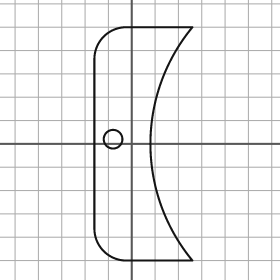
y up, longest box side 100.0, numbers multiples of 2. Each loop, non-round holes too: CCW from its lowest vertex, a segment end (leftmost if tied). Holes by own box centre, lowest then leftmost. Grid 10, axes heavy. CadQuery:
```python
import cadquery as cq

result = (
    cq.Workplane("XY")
    .moveTo(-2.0, -50.0)
    .lineTo(26.0, -50.0)
    .threePointArc((8.0, 0.0), (26.0, 50.0))
    .lineTo(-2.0, 50.0)
    .threePointArc((-12.0, 46.0), (-16.0, 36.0))
    .lineTo(-16.0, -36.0)
    .threePointArc((-12.0, -46.0), (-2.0, -50.0))
    .close()
    .moveTo(-8.0, 2.0)
    .circle(4.0)
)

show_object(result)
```